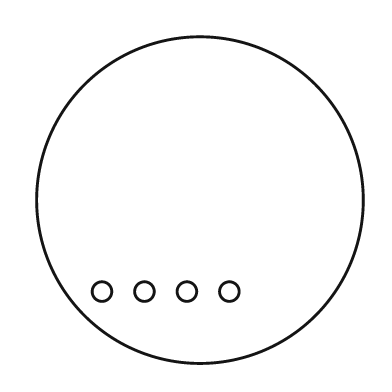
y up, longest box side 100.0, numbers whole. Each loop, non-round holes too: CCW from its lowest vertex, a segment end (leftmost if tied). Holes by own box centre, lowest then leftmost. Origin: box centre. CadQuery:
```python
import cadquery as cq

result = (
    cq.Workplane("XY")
    .moveTo(0.0, 0.0)
    .circle(50.0)
    .moveTo(-30.0, -28.0)
    .circle(3.0)
    .moveTo(-17.0, -28.0)
    .circle(3.0)
    .moveTo(-4.0, -28.0)
    .circle(3.0)
    .moveTo(9.0, -28.0)
    .circle(3.0)
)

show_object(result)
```